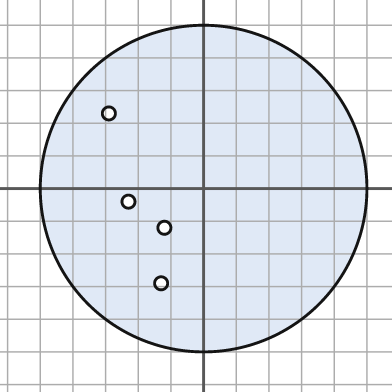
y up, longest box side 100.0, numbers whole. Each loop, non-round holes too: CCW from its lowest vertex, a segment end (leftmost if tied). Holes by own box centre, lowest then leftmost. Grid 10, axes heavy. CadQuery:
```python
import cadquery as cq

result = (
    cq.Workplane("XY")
    .moveTo(0.0, 0.0)
    .circle(50.0)
    .moveTo(-13.0, -29.0)
    .circle(2.0)
    .moveTo(-12.0, -12.0)
    .circle(2.0)
    .moveTo(-23.0, -4.0)
    .circle(2.0)
    .moveTo(-29.0, 23.0)
    .circle(2.0)
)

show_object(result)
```